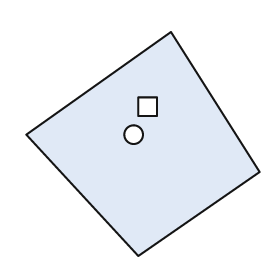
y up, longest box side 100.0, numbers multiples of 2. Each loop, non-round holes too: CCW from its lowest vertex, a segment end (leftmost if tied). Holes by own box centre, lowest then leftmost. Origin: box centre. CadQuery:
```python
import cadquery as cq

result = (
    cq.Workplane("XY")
    .moveTo(-2.0, -48.0)
    .lineTo(50.0, -12.0)
    .lineTo(12.0, 48.0)
    .lineTo(-50.0, 4.0)
    .close()
    .moveTo(-4.0, 4.0)
    .circle(4.0)
    .moveTo(-2.0, 12.0)
    .lineTo(6.0, 12.0)
    .lineTo(6.0, 20.0)
    .lineTo(-2.0, 20.0)
    .close()
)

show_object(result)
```